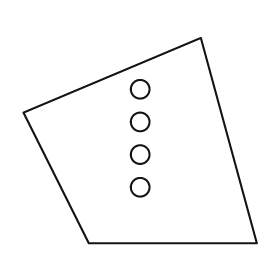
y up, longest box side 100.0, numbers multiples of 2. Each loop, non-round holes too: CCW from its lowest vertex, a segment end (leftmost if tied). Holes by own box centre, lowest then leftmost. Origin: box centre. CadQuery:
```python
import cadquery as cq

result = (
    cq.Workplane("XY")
    .moveTo(-22.0, -44.0)
    .lineTo(50.0, -44.0)
    .lineTo(26.0, 44.0)
    .lineTo(-50.0, 12.0)
    .close()
    .moveTo(0.0, -20.0)
    .circle(4.0)
    .moveTo(0.0, -6.0)
    .circle(4.0)
    .moveTo(0.0, 8.0)
    .circle(4.0)
    .moveTo(0.0, 22.0)
    .circle(4.0)
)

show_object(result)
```